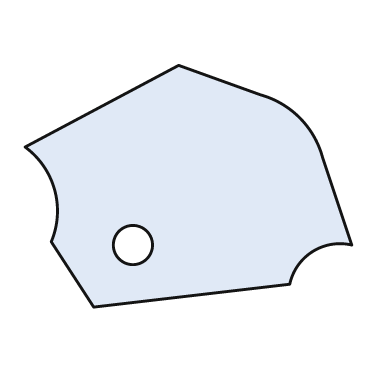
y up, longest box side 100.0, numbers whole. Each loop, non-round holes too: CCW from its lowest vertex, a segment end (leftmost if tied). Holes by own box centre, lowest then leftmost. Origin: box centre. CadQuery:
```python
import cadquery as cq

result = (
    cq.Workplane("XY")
    .moveTo(-29.0, -37.0)
    .lineTo(31.0, -30.0)
    .threePointArc((38.0, -20.0), (50.0, -18.0))
    .lineTo(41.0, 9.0)
    .threePointArc((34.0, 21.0), (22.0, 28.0))
    .lineTo(-3.0, 37.0)
    .lineTo(-50.0, 12.0)
    .threePointArc((-41.0, -1.0), (-42.0, -17.0))
    .close()
    .moveTo(-17.0, -18.0)
    .circle(6.0)
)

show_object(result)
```